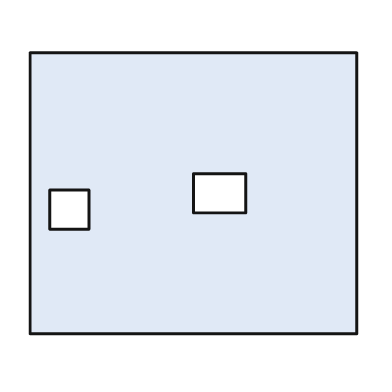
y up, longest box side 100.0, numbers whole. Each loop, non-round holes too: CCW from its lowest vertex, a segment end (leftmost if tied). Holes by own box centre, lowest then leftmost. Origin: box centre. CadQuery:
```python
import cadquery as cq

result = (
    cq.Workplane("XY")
    .moveTo(-50.0, -43.0)
    .lineTo(50.0, -43.0)
    .lineTo(50.0, 43.0)
    .lineTo(-50.0, 43.0)
    .close()
    .moveTo(-44.0, -11.0)
    .lineTo(-32.0, -11.0)
    .lineTo(-32.0, 1.0)
    .lineTo(-44.0, 1.0)
    .close()
    .moveTo(0.0, -6.0)
    .lineTo(16.0, -6.0)
    .lineTo(16.0, 6.0)
    .lineTo(0.0, 6.0)
    .close()
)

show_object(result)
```